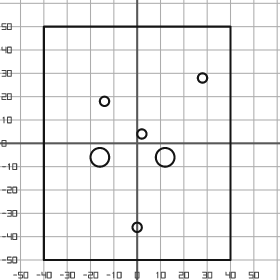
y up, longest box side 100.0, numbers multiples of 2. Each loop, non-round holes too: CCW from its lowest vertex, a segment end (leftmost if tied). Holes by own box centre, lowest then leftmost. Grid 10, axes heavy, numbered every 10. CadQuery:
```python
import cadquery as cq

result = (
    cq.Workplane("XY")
    .moveTo(-40.0, -50.0)
    .lineTo(40.0, -50.0)
    .lineTo(40.0, 50.0)
    .lineTo(-40.0, 50.0)
    .close()
    .moveTo(0.0, -36.0)
    .circle(2.0)
    .moveTo(-16.0, -6.0)
    .circle(4.0)
    .moveTo(12.0, -6.0)
    .circle(4.0)
    .moveTo(2.0, 4.0)
    .circle(2.0)
    .moveTo(-14.0, 18.0)
    .circle(2.0)
    .moveTo(28.0, 28.0)
    .circle(2.0)
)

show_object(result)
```